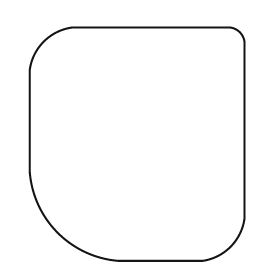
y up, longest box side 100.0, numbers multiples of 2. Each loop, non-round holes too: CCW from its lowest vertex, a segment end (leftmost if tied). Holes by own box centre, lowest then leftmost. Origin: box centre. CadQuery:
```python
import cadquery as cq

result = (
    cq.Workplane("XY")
    .moveTo(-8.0, -50.0)
    .lineTo(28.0, -50.0)
    .threePointArc((40.0, -44.0), (46.0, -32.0))
    .lineTo(46.0, 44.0)
    .threePointArc((44.0, 48.0), (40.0, 50.0))
    .lineTo(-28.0, 50.0)
    .threePointArc((-40.0, 44.0), (-46.0, 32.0))
    .lineTo(-46.0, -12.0)
    .threePointArc((-34.0, -38.0), (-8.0, -50.0))
    .close()
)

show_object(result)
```